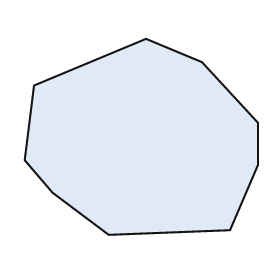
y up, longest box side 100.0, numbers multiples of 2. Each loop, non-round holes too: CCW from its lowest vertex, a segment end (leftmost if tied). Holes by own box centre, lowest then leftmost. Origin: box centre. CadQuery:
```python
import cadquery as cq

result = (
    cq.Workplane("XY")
    .moveTo(-14.0, -42.0)
    .lineTo(38.0, -40.0)
    .lineTo(50.0, -12.0)
    .lineTo(50.0, 6.0)
    .lineTo(26.0, 32.0)
    .lineTo(2.0, 42.0)
    .lineTo(-46.0, 22.0)
    .lineTo(-50.0, -10.0)
    .lineTo(-38.0, -24.0)
    .close()
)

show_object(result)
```